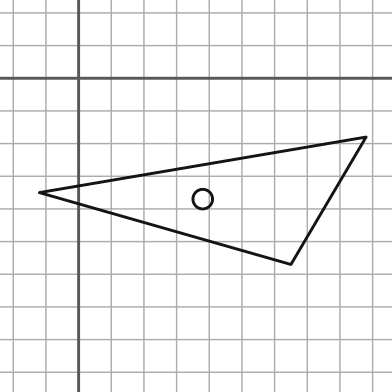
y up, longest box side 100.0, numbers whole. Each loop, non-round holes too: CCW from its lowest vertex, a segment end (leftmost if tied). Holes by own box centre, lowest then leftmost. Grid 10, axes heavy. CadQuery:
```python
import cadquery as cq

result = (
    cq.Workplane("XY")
    .moveTo(65.0, -57.0)
    .lineTo(88.0, -18.0)
    .lineTo(-12.0, -35.0)
    .close()
    .moveTo(38.0, -37.0)
    .circle(3.0)
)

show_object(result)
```